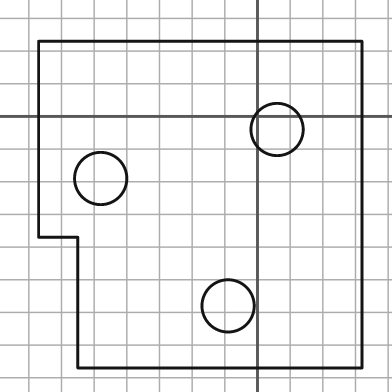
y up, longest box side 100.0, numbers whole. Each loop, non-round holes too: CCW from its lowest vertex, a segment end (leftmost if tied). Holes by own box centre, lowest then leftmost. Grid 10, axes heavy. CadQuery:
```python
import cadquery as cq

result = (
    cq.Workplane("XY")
    .moveTo(-55.0, -77.0)
    .lineTo(32.0, -77.0)
    .lineTo(32.0, 23.0)
    .lineTo(-67.0, 23.0)
    .lineTo(-67.0, -37.0)
    .lineTo(-55.0, -37.0)
    .close()
    .moveTo(-9.0, -58.0)
    .circle(8.0)
    .moveTo(-48.0, -19.0)
    .circle(8.0)
    .moveTo(6.0, -4.0)
    .circle(8.0)
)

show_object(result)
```